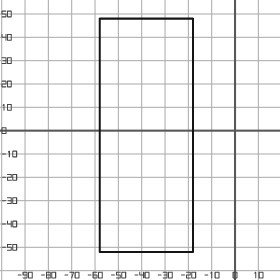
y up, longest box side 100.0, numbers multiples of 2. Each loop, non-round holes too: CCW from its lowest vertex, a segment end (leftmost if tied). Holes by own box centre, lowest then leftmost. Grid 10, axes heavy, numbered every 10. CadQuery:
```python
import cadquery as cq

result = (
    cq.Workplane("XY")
    .moveTo(-58.0, -52.0)
    .lineTo(-18.0, -52.0)
    .lineTo(-18.0, 48.0)
    .lineTo(-58.0, 48.0)
    .close()
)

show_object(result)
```